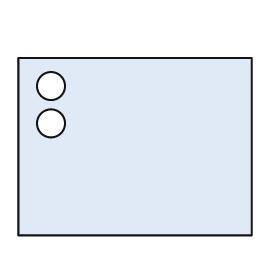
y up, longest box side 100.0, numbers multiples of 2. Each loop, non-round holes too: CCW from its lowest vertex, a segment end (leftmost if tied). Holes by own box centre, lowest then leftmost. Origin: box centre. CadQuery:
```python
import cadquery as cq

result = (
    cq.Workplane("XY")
    .moveTo(-50.0, -38.0)
    .lineTo(50.0, -38.0)
    .lineTo(50.0, 38.0)
    .lineTo(-50.0, 38.0)
    .close()
    .moveTo(-36.0, 10.0)
    .circle(6.0)
    .moveTo(-36.0, 26.0)
    .circle(6.0)
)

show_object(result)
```